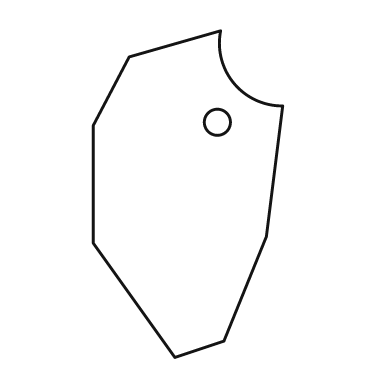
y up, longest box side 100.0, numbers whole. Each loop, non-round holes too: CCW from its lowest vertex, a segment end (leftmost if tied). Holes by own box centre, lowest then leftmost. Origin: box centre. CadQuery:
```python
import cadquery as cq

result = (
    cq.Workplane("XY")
    .moveTo(-4.0, -50.0)
    .lineTo(11.0, -45.0)
    .lineTo(24.0, -13.0)
    .lineTo(29.0, 27.0)
    .threePointArc((14.0, 34.0), (10.0, 50.0))
    .lineTo(-18.0, 42.0)
    .lineTo(-29.0, 21.0)
    .lineTo(-29.0, -15.0)
    .close()
    .moveTo(9.0, 22.0)
    .circle(4.0)
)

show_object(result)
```